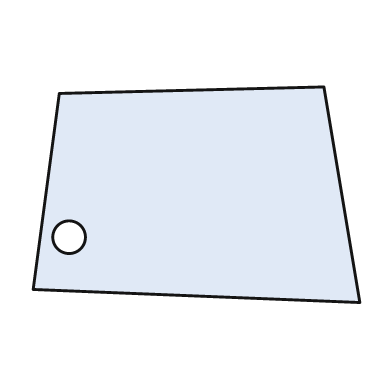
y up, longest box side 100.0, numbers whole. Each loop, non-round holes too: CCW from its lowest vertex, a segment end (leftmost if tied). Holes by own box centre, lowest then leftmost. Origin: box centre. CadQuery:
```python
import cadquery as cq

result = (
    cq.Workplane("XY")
    .moveTo(50.0, -33.0)
    .lineTo(39.0, 33.0)
    .lineTo(-42.0, 31.0)
    .lineTo(-50.0, -29.0)
    .close()
    .moveTo(-39.0, -13.0)
    .circle(5.0)
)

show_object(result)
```